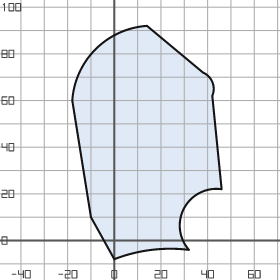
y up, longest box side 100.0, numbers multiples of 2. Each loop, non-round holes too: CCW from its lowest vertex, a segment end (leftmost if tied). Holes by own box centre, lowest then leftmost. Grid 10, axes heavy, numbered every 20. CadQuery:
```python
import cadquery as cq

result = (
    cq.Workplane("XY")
    .moveTo(0.0, -8.0)
    .threePointArc((16.0, -4.0), (32.0, -4.0))
    .threePointArc((30.0, 14.0), (46.0, 22.0))
    .lineTo(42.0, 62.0)
    .threePointArc((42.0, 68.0), (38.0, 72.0))
    .lineTo(14.0, 92.0)
    .threePointArc((-8.0, 82.0), (-18.0, 60.0))
    .lineTo(-10.0, 10.0)
    .close()
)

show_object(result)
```